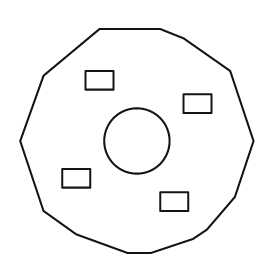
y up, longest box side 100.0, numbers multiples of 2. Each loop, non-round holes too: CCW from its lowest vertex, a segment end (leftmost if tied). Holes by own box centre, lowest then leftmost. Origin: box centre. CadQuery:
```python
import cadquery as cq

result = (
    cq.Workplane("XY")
    .moveTo(-4.0, -48.0)
    .lineTo(6.0, -48.0)
    .lineTo(24.0, -42.0)
    .lineTo(30.0, -38.0)
    .lineTo(42.0, -24.0)
    .lineTo(50.0, 0.0)
    .lineTo(40.0, 30.0)
    .lineTo(20.0, 44.0)
    .lineTo(10.0, 48.0)
    .lineTo(-16.0, 48.0)
    .lineTo(-40.0, 28.0)
    .lineTo(-50.0, 0.0)
    .lineTo(-40.0, -30.0)
    .lineTo(-26.0, -40.0)
    .close()
    .moveTo(10.0, -30.0)
    .lineTo(22.0, -30.0)
    .lineTo(22.0, -22.0)
    .lineTo(10.0, -22.0)
    .close()
    .moveTo(-32.0, -20.0)
    .lineTo(-20.0, -20.0)
    .lineTo(-20.0, -12.0)
    .lineTo(-32.0, -12.0)
    .close()
    .moveTo(0.0, 0.0)
    .circle(14.0)
    .moveTo(20.0, 12.0)
    .lineTo(32.0, 12.0)
    .lineTo(32.0, 20.0)
    .lineTo(20.0, 20.0)
    .close()
    .moveTo(-22.0, 22.0)
    .lineTo(-10.0, 22.0)
    .lineTo(-10.0, 30.0)
    .lineTo(-22.0, 30.0)
    .close()
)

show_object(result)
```